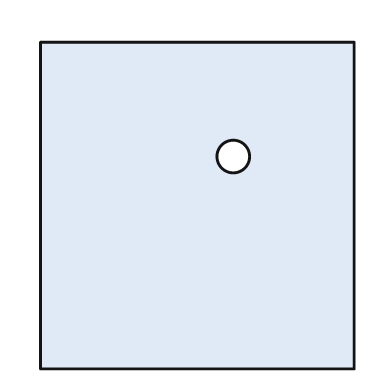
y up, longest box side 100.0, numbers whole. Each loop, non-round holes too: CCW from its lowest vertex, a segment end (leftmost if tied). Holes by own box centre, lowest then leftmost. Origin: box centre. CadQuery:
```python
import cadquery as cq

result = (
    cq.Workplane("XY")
    .moveTo(-48.0, -50.0)
    .lineTo(48.0, -50.0)
    .lineTo(48.0, 50.0)
    .lineTo(-48.0, 50.0)
    .close()
    .moveTo(11.0, 15.0)
    .circle(5.0)
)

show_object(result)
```